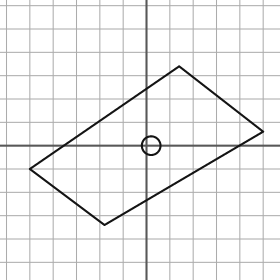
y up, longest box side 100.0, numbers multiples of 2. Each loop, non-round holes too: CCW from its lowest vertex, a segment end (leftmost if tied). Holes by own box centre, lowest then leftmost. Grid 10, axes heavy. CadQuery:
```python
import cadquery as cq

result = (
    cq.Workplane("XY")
    .moveTo(-18.0, -34.0)
    .lineTo(50.0, 6.0)
    .lineTo(14.0, 34.0)
    .lineTo(-50.0, -10.0)
    .close()
    .moveTo(2.0, 0.0)
    .circle(4.0)
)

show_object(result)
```